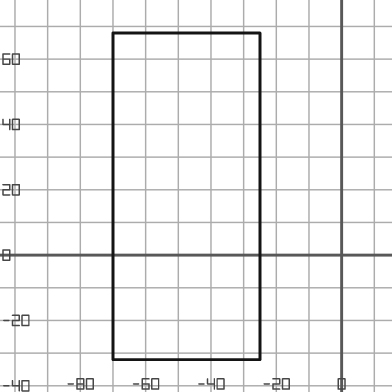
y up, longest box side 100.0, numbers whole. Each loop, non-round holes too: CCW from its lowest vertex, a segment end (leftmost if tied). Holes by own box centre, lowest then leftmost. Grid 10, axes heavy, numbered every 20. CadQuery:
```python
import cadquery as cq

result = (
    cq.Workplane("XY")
    .moveTo(-70.0, -32.0)
    .lineTo(-25.0, -32.0)
    .lineTo(-25.0, 68.0)
    .lineTo(-70.0, 68.0)
    .close()
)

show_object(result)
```